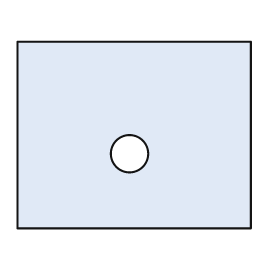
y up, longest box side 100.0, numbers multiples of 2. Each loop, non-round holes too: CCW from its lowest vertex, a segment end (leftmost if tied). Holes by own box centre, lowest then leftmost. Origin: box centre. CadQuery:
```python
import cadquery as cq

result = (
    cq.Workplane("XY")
    .moveTo(-50.0, -40.0)
    .lineTo(50.0, -40.0)
    .lineTo(50.0, 40.0)
    .lineTo(-50.0, 40.0)
    .close()
    .moveTo(-2.0, -8.0)
    .circle(8.0)
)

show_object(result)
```